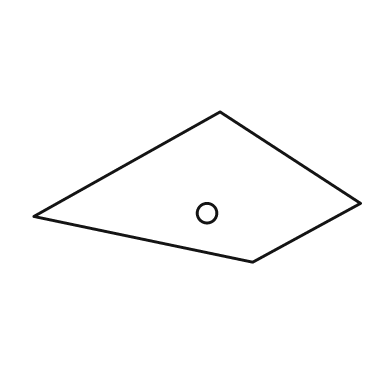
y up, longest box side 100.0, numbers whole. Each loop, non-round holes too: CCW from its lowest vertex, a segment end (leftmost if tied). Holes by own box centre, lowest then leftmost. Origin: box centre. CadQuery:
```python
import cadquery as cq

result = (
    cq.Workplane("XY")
    .moveTo(17.0, -23.0)
    .lineTo(50.0, -5.0)
    .lineTo(7.0, 23.0)
    .lineTo(-50.0, -9.0)
    .close()
    .moveTo(3.0, -8.0)
    .circle(3.0)
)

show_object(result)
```